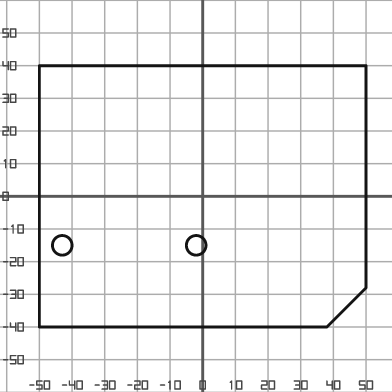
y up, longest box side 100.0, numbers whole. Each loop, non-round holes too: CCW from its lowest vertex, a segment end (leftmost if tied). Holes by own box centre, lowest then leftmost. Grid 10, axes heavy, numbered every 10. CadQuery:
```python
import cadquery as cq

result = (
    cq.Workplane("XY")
    .moveTo(-50.0, -40.0)
    .lineTo(38.0, -40.0)
    .lineTo(50.0, -28.0)
    .lineTo(50.0, 40.0)
    .lineTo(-50.0, 40.0)
    .close()
    .moveTo(-43.0, -15.0)
    .circle(3.0)
    .moveTo(-2.0, -15.0)
    .circle(3.0)
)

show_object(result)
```